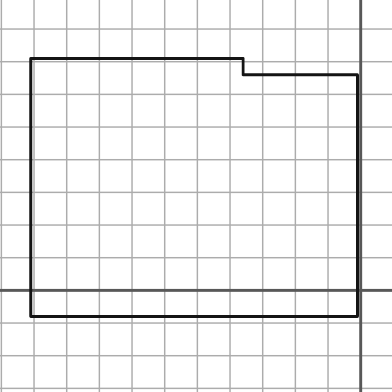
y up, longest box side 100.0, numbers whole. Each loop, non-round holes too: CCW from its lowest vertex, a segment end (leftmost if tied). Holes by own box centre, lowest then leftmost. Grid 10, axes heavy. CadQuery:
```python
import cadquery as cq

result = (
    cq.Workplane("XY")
    .moveTo(-101.0, -8.0)
    .lineTo(-1.0, -8.0)
    .lineTo(-1.0, 66.0)
    .lineTo(-36.0, 66.0)
    .lineTo(-36.0, 71.0)
    .lineTo(-101.0, 71.0)
    .close()
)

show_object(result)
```